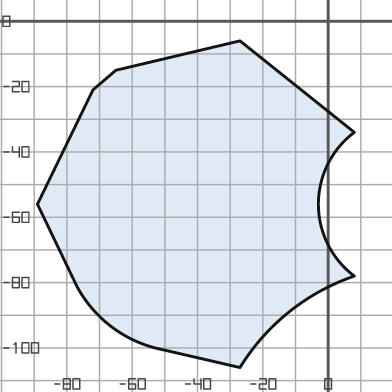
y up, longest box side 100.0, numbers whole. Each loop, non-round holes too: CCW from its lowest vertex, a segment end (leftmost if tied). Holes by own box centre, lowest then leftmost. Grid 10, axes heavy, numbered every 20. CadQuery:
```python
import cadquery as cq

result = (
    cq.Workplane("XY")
    .moveTo(-27.0, -106.0)
    .threePointArc((-12.0, -89.0), (8.0, -78.0))
    .threePointArc((-3.0, -56.0), (8.0, -34.0))
    .lineTo(-27.0, -6.0)
    .lineTo(-65.0, -15.0)
    .lineTo(-72.0, -21.0)
    .lineTo(-89.0, -56.0)
    .lineTo(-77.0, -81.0)
    .threePointArc((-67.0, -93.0), (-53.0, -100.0))
    .close()
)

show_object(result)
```